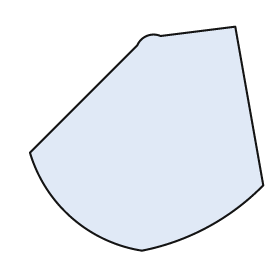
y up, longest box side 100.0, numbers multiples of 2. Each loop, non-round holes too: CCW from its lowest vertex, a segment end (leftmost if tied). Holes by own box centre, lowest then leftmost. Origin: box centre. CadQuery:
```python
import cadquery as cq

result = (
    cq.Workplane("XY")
    .moveTo(-2.0, -48.0)
    .threePointArc((26.0, -38.0), (50.0, -20.0))
    .lineTo(38.0, 48.0)
    .lineTo(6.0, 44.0)
    .threePointArc((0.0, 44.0), (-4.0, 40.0))
    .lineTo(-50.0, -6.0)
    .threePointArc((-32.0, -34.0), (-2.0, -48.0))
    .close()
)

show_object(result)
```